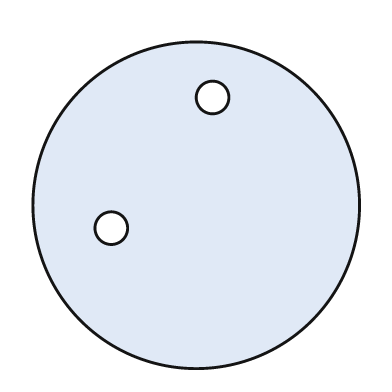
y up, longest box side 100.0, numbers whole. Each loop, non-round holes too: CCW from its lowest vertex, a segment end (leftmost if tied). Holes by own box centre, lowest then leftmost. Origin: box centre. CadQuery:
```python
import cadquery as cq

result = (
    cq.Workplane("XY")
    .moveTo(0.0, 0.0)
    .circle(50.0)
    .moveTo(-26.0, -7.0)
    .circle(5.0)
    .moveTo(5.0, 33.0)
    .circle(5.0)
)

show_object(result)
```